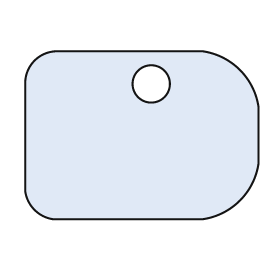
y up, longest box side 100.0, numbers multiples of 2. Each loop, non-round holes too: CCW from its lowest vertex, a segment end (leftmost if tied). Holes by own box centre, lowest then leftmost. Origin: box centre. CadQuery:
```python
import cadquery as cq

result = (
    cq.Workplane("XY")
    .moveTo(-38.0, -36.0)
    .lineTo(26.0, -36.0)
    .threePointArc((42.0, -28.0), (50.0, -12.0))
    .lineTo(50.0, 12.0)
    .threePointArc((42.0, 28.0), (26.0, 36.0))
    .lineTo(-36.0, 36.0)
    .threePointArc((-46.0, 32.0), (-50.0, 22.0))
    .lineTo(-50.0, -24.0)
    .threePointArc((-46.0, -32.0), (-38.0, -36.0))
    .close()
    .moveTo(4.0, 22.0)
    .circle(8.0)
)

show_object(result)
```